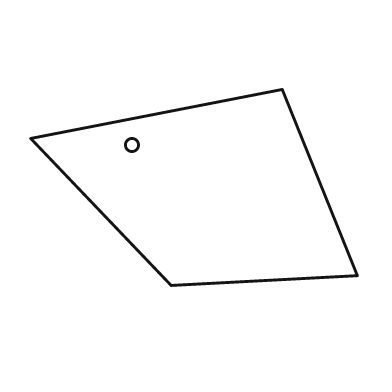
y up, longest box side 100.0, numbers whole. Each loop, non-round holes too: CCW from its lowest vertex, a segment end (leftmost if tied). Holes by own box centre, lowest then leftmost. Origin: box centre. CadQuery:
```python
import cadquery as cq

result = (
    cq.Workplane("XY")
    .moveTo(-7.0, -30.0)
    .lineTo(50.0, -27.0)
    .lineTo(27.0, 30.0)
    .lineTo(-50.0, 15.0)
    .close()
    .moveTo(-19.0, 13.0)
    .circle(2.0)
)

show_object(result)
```